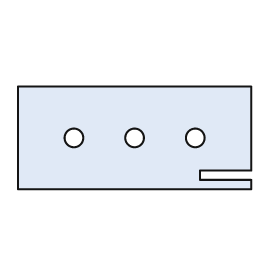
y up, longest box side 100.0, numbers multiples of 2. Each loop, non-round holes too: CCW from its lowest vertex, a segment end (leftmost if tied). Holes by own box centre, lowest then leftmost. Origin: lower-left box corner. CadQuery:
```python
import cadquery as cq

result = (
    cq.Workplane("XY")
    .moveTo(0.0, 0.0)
    .lineTo(100.0, 0.0)
    .lineTo(100.0, 4.0)
    .lineTo(78.0, 4.0)
    .lineTo(78.0, 8.0)
    .lineTo(100.0, 8.0)
    .lineTo(100.0, 44.0)
    .lineTo(0.0, 44.0)
    .close()
    .moveTo(24.0, 22.0)
    .circle(4.0)
    .moveTo(50.0, 22.0)
    .circle(4.0)
    .moveTo(76.0, 22.0)
    .circle(4.0)
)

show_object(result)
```